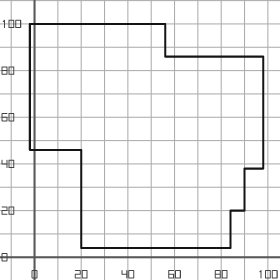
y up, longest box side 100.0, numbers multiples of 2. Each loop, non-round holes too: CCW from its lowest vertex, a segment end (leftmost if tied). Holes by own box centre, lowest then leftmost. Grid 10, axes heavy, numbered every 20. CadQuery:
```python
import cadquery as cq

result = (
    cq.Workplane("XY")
    .moveTo(20.0, 4.0)
    .lineTo(84.0, 4.0)
    .lineTo(84.0, 20.0)
    .lineTo(90.0, 20.0)
    .lineTo(90.0, 38.0)
    .lineTo(98.0, 38.0)
    .lineTo(98.0, 86.0)
    .lineTo(56.0, 86.0)
    .lineTo(56.0, 100.0)
    .lineTo(-2.0, 100.0)
    .lineTo(-2.0, 46.0)
    .lineTo(20.0, 46.0)
    .close()
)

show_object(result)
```